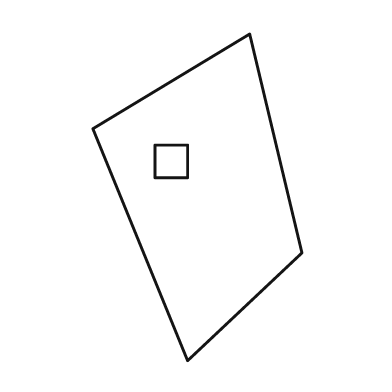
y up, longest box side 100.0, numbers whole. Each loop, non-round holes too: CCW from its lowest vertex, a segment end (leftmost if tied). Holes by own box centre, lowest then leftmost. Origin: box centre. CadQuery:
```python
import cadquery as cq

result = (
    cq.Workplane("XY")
    .moveTo(-3.0, -50.0)
    .lineTo(32.0, -17.0)
    .lineTo(16.0, 50.0)
    .lineTo(-32.0, 21.0)
    .close()
    .moveTo(-13.0, 6.0)
    .lineTo(-3.0, 6.0)
    .lineTo(-3.0, 16.0)
    .lineTo(-13.0, 16.0)
    .close()
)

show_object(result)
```